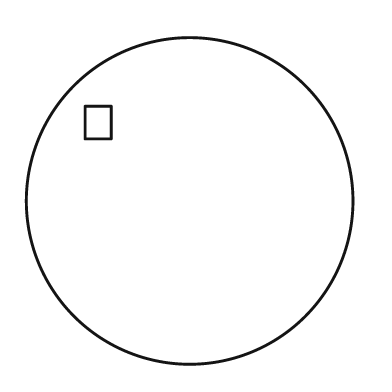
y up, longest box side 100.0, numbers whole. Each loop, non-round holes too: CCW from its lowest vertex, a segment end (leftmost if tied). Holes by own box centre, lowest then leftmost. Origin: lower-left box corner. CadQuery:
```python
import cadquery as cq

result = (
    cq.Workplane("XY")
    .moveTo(50.0, 50.0)
    .circle(50.0)
    .moveTo(18.0, 69.0)
    .lineTo(26.0, 69.0)
    .lineTo(26.0, 79.0)
    .lineTo(18.0, 79.0)
    .close()
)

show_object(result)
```